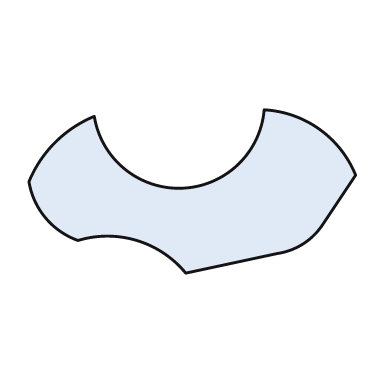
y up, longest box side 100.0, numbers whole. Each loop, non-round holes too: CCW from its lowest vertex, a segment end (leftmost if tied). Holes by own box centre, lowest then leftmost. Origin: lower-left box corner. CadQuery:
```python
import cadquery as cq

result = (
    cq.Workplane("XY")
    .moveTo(48.0, 0.0)
    .lineTo(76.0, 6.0)
    .threePointArc((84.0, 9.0), (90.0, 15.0))
    .lineTo(100.0, 30.0)
    .threePointArc((89.0, 44.0), (72.0, 50.0))
    .threePointArc((47.0, 26.0), (20.0, 48.0))
    .threePointArc((8.0, 40.0), (0.0, 28.0))
    .threePointArc((5.0, 17.0), (15.0, 10.0))
    .threePointArc((33.0, 10.0), (48.0, 0.0))
    .close()
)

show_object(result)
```